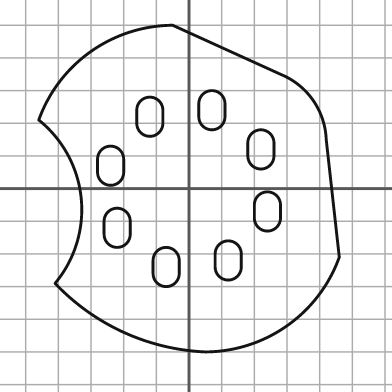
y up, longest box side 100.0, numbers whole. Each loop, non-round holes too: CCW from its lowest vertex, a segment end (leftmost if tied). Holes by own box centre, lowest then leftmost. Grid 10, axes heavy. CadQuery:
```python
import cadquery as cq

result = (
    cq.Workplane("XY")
    .moveTo(5.0, -50.0)
    .threePointArc((30.0, -42.0), (46.0, -21.0))
    .lineTo(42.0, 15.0)
    .threePointArc((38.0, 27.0), (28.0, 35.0))
    .lineTo(-5.0, 50.0)
    .threePointArc((-30.0, 42.0), (-46.0, 21.0))
    .threePointArc((-33.0, -3.0), (-41.0, -29.0))
    .threePointArc((-20.0, -44.0), (5.0, -50.0))
    .close()
    .moveTo(-11.0, -26.0)
    .threePointArc((-7.0, -30.0), (-3.0, -26.0))
    .lineTo(-3.0, -22.0)
    .threePointArc((-7.0, -18.0), (-11.0, -22.0))
    .close()
    .moveTo(8.0, -24.0)
    .threePointArc((12.0, -28.0), (16.0, -24.0))
    .lineTo(16.0, -20.0)
    .threePointArc((12.0, -16.0), (8.0, -20.0))
    .close()
    .moveTo(-26.0, -14.0)
    .threePointArc((-22.0, -18.0), (-18.0, -14.0))
    .lineTo(-18.0, -10.0)
    .threePointArc((-22.0, -6.0), (-26.0, -10.0))
    .close()
    .moveTo(20.0, -9.0)
    .threePointArc((24.0, -13.0), (28.0, -9.0))
    .lineTo(28.0, -5.0)
    .threePointArc((24.0, -1.0), (20.0, -5.0))
    .close()
    .moveTo(-28.0, 5.0)
    .threePointArc((-24.0, 1.0), (-20.0, 5.0))
    .lineTo(-20.0, 9.0)
    .threePointArc((-24.0, 13.0), (-28.0, 9.0))
    .close()
    .moveTo(18.0, 10.0)
    .threePointArc((22.0, 6.0), (26.0, 10.0))
    .lineTo(26.0, 14.0)
    .threePointArc((22.0, 18.0), (18.0, 14.0))
    .close()
    .moveTo(-16.0, 20.0)
    .threePointArc((-12.0, 16.0), (-8.0, 20.0))
    .lineTo(-8.0, 24.0)
    .threePointArc((-12.0, 28.0), (-16.0, 24.0))
    .close()
    .moveTo(3.0, 22.0)
    .threePointArc((7.0, 18.0), (11.0, 22.0))
    .lineTo(11.0, 26.0)
    .threePointArc((7.0, 30.0), (3.0, 26.0))
    .close()
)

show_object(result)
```